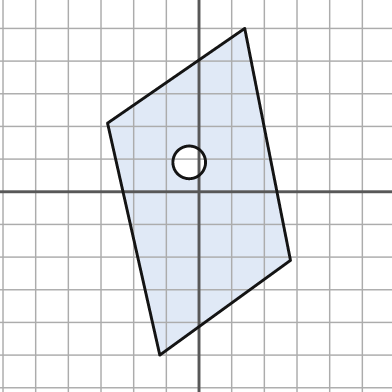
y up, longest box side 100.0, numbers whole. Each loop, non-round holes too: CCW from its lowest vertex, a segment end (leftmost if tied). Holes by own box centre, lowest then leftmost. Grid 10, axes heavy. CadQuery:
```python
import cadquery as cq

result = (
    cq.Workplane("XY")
    .moveTo(-12.0, -50.0)
    .lineTo(28.0, -21.0)
    .lineTo(14.0, 50.0)
    .lineTo(-28.0, 21.0)
    .close()
    .moveTo(-3.0, 9.0)
    .circle(5.0)
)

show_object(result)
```